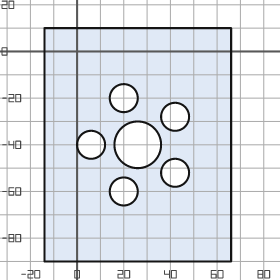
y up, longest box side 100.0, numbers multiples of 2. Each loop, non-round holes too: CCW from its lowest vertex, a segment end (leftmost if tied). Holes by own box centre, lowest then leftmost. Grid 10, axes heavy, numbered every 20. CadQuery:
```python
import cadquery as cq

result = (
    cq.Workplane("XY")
    .moveTo(-14.0, -90.0)
    .lineTo(66.0, -90.0)
    .lineTo(66.0, 10.0)
    .lineTo(-14.0, 10.0)
    .close()
    .moveTo(20.0, -60.0)
    .circle(6.0)
    .moveTo(42.0, -52.0)
    .circle(6.0)
    .moveTo(6.0, -40.0)
    .circle(6.0)
    .moveTo(26.0, -40.0)
    .circle(10.0)
    .moveTo(42.0, -28.0)
    .circle(6.0)
    .moveTo(20.0, -20.0)
    .circle(6.0)
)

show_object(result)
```